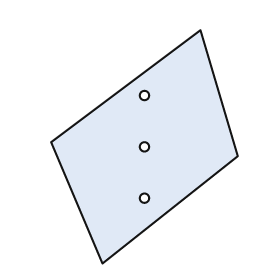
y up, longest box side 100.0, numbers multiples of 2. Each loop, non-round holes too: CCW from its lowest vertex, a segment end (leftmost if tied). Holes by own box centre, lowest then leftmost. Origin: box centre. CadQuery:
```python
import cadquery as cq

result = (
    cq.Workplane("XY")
    .moveTo(-18.0, -50.0)
    .lineTo(40.0, -4.0)
    .lineTo(24.0, 50.0)
    .lineTo(-40.0, 2.0)
    .close()
    .moveTo(0.0, -22.0)
    .circle(2.0)
    .moveTo(0.0, 0.0)
    .circle(2.0)
    .moveTo(0.0, 22.0)
    .circle(2.0)
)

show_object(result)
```